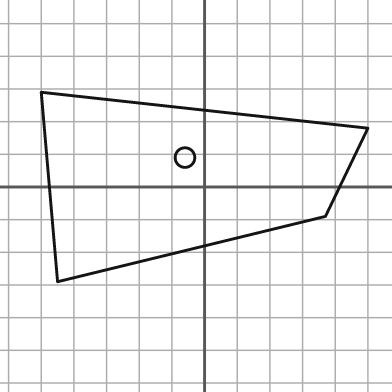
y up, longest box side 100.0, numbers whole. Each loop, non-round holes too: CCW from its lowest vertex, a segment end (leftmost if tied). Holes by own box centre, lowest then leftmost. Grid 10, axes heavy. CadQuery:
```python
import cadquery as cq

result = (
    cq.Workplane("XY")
    .moveTo(-45.0, -29.0)
    .lineTo(37.0, -9.0)
    .lineTo(50.0, 18.0)
    .lineTo(-50.0, 29.0)
    .close()
    .moveTo(-6.0, 9.0)
    .circle(3.0)
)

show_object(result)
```